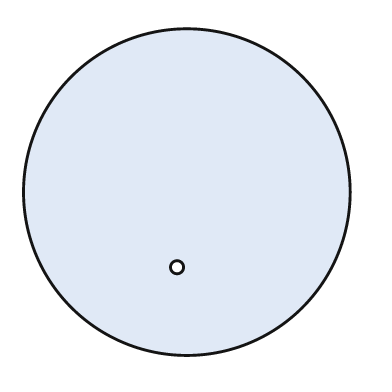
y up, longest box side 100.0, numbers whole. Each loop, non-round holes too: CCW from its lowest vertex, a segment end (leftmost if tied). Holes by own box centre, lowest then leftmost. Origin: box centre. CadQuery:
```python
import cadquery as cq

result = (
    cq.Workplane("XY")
    .moveTo(0.0, 0.0)
    .circle(50.0)
    .moveTo(-3.0, -23.0)
    .circle(2.0)
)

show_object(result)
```